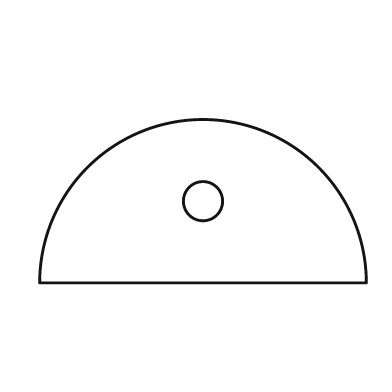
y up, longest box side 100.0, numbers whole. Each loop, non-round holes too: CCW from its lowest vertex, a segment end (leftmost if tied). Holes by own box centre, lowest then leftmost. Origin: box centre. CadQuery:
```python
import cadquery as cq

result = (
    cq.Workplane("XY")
    .moveTo(-50.0, -25.0)
    .lineTo(50.0, -25.0)
    .threePointArc((0.0, 25.0), (-50.0, -25.0))
    .close()
    .moveTo(0.0, 0.0)
    .circle(6.0)
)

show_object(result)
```